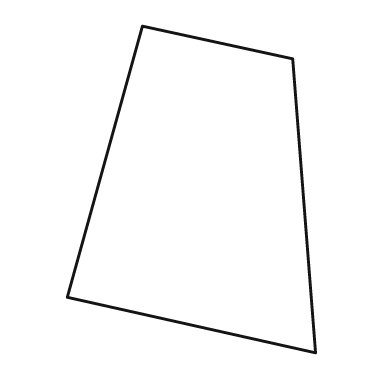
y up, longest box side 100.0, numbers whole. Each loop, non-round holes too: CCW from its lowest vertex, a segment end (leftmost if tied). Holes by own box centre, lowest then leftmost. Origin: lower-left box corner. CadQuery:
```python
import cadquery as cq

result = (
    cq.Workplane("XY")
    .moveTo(76.0, 0.0)
    .lineTo(69.0, 90.0)
    .lineTo(23.0, 100.0)
    .lineTo(0.0, 17.0)
    .close()
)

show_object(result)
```